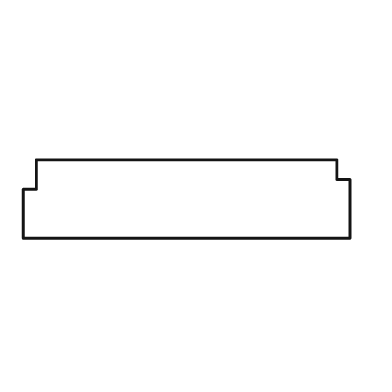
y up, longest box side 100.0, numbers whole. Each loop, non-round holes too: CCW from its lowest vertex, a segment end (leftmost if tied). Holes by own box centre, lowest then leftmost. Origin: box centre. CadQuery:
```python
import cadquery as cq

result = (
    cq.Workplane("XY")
    .moveTo(-50.0, -12.0)
    .lineTo(50.0, -12.0)
    .lineTo(50.0, 6.0)
    .lineTo(46.0, 6.0)
    .lineTo(46.0, 12.0)
    .lineTo(-46.0, 12.0)
    .lineTo(-46.0, 3.0)
    .lineTo(-50.0, 3.0)
    .close()
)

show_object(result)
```